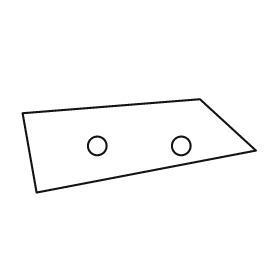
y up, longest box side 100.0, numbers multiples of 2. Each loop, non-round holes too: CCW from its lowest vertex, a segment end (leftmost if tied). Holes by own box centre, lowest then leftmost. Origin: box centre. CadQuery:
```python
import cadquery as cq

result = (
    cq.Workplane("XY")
    .moveTo(-44.0, -20.0)
    .lineTo(50.0, -2.0)
    .lineTo(26.0, 20.0)
    .lineTo(-50.0, 14.0)
    .close()
    .moveTo(-18.0, 0.0)
    .circle(4.0)
    .moveTo(18.0, 0.0)
    .circle(4.0)
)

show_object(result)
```